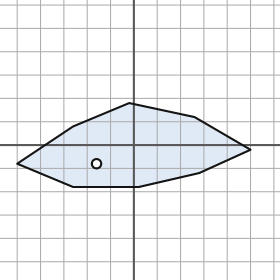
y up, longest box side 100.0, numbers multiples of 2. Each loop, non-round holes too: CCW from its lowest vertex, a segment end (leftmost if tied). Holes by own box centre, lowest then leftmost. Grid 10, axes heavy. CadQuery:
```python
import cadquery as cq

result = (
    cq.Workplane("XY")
    .moveTo(-26.0, -18.0)
    .lineTo(2.0, -18.0)
    .lineTo(28.0, -12.0)
    .lineTo(50.0, -2.0)
    .lineTo(26.0, 12.0)
    .lineTo(-2.0, 18.0)
    .lineTo(-26.0, 8.0)
    .lineTo(-50.0, -8.0)
    .close()
    .moveTo(-16.0, -8.0)
    .circle(2.0)
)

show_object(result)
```